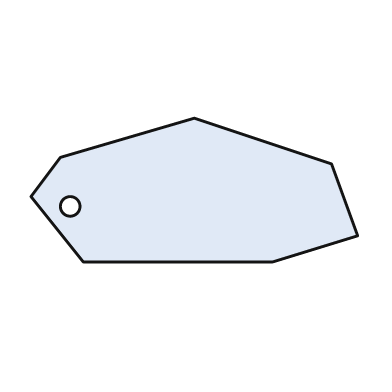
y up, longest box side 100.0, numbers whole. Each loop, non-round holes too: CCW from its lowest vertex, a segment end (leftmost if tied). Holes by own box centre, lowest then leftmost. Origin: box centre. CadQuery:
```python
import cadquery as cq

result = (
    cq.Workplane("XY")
    .moveTo(-34.0, -22.0)
    .lineTo(24.0, -22.0)
    .lineTo(50.0, -14.0)
    .lineTo(42.0, 8.0)
    .lineTo(0.0, 22.0)
    .lineTo(-41.0, 10.0)
    .lineTo(-50.0, -2.0)
    .close()
    .moveTo(-38.0, -5.0)
    .circle(3.0)
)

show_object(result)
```